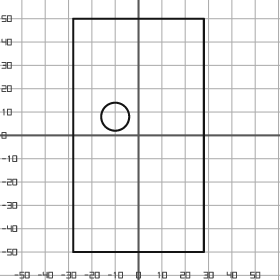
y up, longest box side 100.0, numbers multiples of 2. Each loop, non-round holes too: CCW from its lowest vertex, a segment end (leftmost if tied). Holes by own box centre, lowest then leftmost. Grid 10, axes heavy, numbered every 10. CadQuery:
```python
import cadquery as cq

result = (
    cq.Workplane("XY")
    .moveTo(-28.0, -50.0)
    .lineTo(28.0, -50.0)
    .lineTo(28.0, 50.0)
    .lineTo(-28.0, 50.0)
    .close()
    .moveTo(-10.0, 8.0)
    .circle(6.0)
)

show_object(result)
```